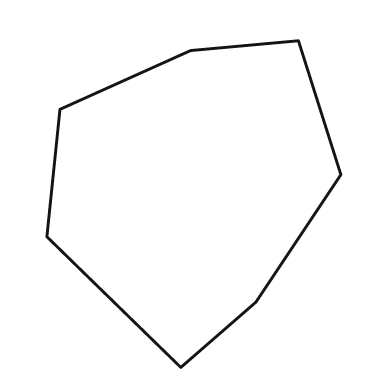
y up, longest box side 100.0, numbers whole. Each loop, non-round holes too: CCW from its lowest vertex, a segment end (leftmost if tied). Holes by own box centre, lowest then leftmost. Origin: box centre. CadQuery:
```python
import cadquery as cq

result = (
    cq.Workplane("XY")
    .moveTo(-4.0, -50.0)
    .lineTo(19.0, -30.0)
    .lineTo(45.0, 9.0)
    .lineTo(32.0, 50.0)
    .lineTo(-1.0, 47.0)
    .lineTo(-41.0, 29.0)
    .lineTo(-45.0, -10.0)
    .close()
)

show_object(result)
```